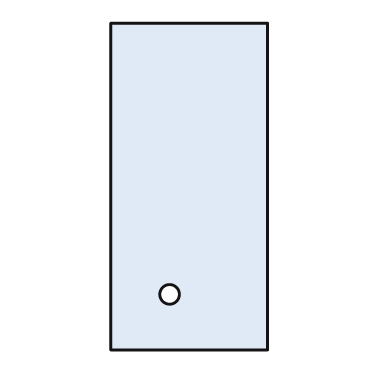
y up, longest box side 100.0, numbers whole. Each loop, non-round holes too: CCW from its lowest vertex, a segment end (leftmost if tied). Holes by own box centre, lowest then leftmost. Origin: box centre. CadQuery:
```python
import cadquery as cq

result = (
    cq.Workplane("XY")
    .moveTo(-24.0, -50.0)
    .lineTo(24.0, -50.0)
    .lineTo(24.0, 50.0)
    .lineTo(-24.0, 50.0)
    .close()
    .moveTo(-6.0, -33.0)
    .circle(3.0)
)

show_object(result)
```